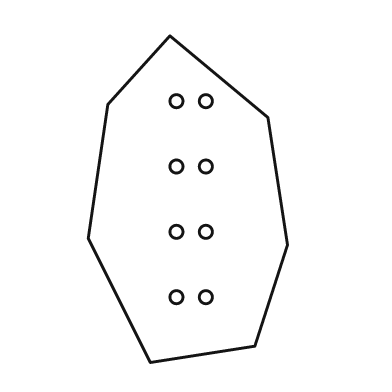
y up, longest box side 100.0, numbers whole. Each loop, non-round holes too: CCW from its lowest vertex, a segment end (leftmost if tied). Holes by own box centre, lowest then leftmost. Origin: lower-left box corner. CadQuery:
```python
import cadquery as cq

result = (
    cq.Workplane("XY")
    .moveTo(19.0, 0.0)
    .lineTo(51.0, 5.0)
    .lineTo(61.0, 36.0)
    .lineTo(55.0, 75.0)
    .lineTo(25.0, 100.0)
    .lineTo(6.0, 79.0)
    .lineTo(0.0, 38.0)
    .close()
    .moveTo(27.0, 20.0)
    .circle(2.0)
    .moveTo(36.0, 20.0)
    .circle(2.0)
    .moveTo(27.0, 40.0)
    .circle(2.0)
    .moveTo(36.0, 40.0)
    .circle(2.0)
    .moveTo(27.0, 60.0)
    .circle(2.0)
    .moveTo(36.0, 60.0)
    .circle(2.0)
    .moveTo(27.0, 80.0)
    .circle(2.0)
    .moveTo(36.0, 80.0)
    .circle(2.0)
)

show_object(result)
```